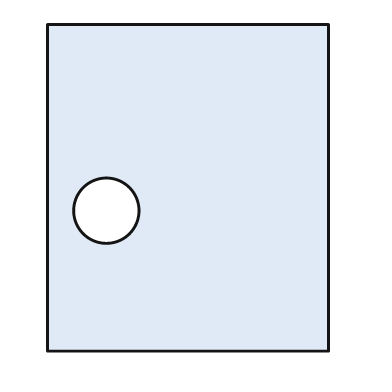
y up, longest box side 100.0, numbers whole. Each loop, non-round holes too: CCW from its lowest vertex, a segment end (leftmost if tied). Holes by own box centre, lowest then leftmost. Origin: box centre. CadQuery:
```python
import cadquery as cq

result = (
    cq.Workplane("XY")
    .moveTo(-43.0, -50.0)
    .lineTo(43.0, -50.0)
    .lineTo(43.0, 50.0)
    .lineTo(-43.0, 50.0)
    .close()
    .moveTo(-25.0, -7.0)
    .circle(10.0)
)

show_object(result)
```